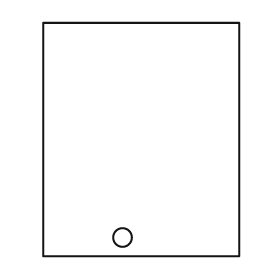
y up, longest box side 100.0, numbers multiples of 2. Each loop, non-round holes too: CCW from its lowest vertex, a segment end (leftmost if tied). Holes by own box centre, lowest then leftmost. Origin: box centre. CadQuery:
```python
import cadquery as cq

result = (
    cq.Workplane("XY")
    .moveTo(-42.0, -50.0)
    .lineTo(42.0, -50.0)
    .lineTo(42.0, 50.0)
    .lineTo(-42.0, 50.0)
    .close()
    .moveTo(-8.0, -42.0)
    .circle(4.0)
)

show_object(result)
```